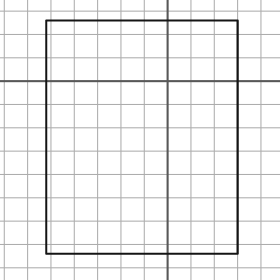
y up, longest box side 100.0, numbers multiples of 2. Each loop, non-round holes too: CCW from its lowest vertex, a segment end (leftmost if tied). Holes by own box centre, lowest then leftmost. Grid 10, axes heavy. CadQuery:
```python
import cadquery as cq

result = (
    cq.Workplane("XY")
    .moveTo(-52.0, -74.0)
    .lineTo(30.0, -74.0)
    .lineTo(30.0, 26.0)
    .lineTo(-52.0, 26.0)
    .close()
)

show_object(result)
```